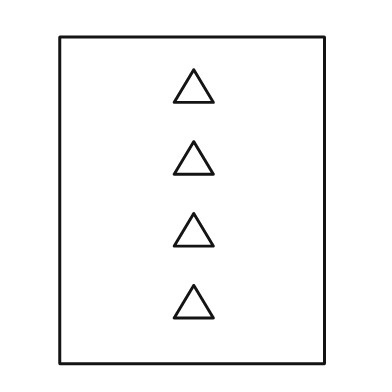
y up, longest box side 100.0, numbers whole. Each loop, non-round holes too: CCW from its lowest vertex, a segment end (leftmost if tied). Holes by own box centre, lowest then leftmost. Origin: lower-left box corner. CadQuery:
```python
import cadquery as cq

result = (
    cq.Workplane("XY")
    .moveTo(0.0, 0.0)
    .lineTo(81.0, 0.0)
    .lineTo(81.0, 100.0)
    .lineTo(0.0, 100.0)
    .close()
    .moveTo(35.0, 14.0)
    .lineTo(47.0, 14.0)
    .lineTo(41.0, 24.0)
    .close()
    .moveTo(35.0, 36.0)
    .lineTo(47.0, 36.0)
    .lineTo(41.0, 46.0)
    .close()
    .moveTo(35.0, 58.0)
    .lineTo(47.0, 58.0)
    .lineTo(41.0, 68.0)
    .close()
    .moveTo(35.0, 80.0)
    .lineTo(47.0, 80.0)
    .lineTo(41.0, 90.0)
    .close()
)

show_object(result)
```